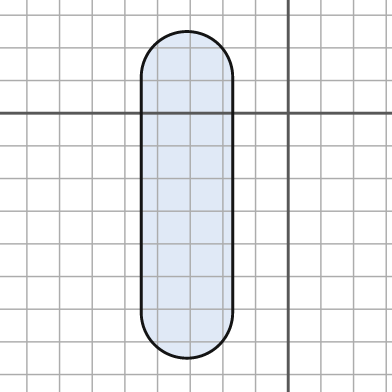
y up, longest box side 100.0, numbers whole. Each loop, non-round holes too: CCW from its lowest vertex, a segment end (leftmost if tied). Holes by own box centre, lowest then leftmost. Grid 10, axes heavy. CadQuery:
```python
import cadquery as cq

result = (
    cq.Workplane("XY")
    .moveTo(-45.0, -61.0)
    .threePointArc((-31.0, -75.0), (-17.0, -61.0))
    .lineTo(-17.0, 11.0)
    .threePointArc((-31.0, 25.0), (-45.0, 11.0))
    .close()
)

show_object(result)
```